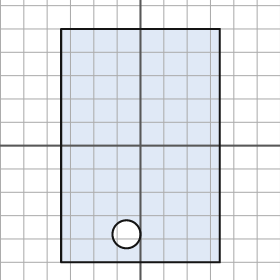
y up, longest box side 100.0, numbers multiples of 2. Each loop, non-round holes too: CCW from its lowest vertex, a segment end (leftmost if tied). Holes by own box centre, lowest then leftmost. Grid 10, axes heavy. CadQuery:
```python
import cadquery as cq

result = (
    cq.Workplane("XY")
    .moveTo(-34.0, -50.0)
    .lineTo(34.0, -50.0)
    .lineTo(34.0, 50.0)
    .lineTo(-34.0, 50.0)
    .close()
    .moveTo(-6.0, -38.0)
    .circle(6.0)
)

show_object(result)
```